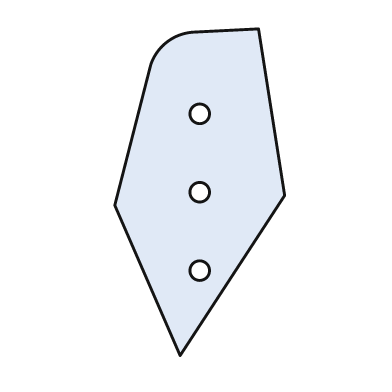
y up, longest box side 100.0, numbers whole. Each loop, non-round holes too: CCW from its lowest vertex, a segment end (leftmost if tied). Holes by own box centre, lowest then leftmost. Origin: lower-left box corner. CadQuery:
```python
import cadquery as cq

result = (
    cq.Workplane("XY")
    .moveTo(20.0, 0.0)
    .lineTo(52.0, 49.0)
    .lineTo(44.0, 100.0)
    .lineTo(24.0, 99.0)
    .threePointArc((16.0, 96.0), (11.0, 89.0))
    .lineTo(0.0, 46.0)
    .close()
    .moveTo(26.0, 26.0)
    .circle(3.0)
    .moveTo(26.0, 50.0)
    .circle(3.0)
    .moveTo(26.0, 74.0)
    .circle(3.0)
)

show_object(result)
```